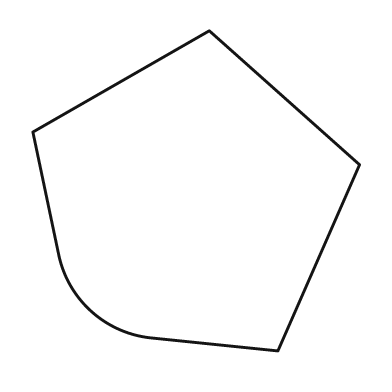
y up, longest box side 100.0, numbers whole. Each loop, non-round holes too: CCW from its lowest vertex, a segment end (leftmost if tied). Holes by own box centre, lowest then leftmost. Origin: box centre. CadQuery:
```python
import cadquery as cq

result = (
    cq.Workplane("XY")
    .moveTo(25.0, -49.0)
    .lineTo(50.0, 8.0)
    .lineTo(4.0, 49.0)
    .lineTo(-50.0, 18.0)
    .lineTo(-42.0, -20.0)
    .threePointArc((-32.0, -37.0), (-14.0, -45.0))
    .close()
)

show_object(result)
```